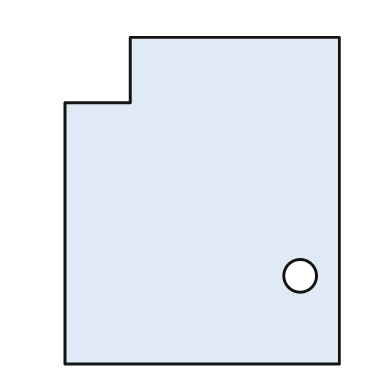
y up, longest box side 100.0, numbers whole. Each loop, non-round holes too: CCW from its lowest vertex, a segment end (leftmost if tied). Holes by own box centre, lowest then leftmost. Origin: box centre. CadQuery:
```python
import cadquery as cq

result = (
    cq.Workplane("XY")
    .moveTo(-42.0, -50.0)
    .lineTo(42.0, -50.0)
    .lineTo(42.0, 50.0)
    .lineTo(-22.0, 50.0)
    .lineTo(-22.0, 30.0)
    .lineTo(-42.0, 30.0)
    .close()
    .moveTo(30.0, -23.0)
    .circle(5.0)
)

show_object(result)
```